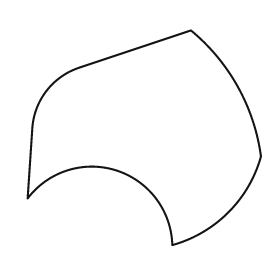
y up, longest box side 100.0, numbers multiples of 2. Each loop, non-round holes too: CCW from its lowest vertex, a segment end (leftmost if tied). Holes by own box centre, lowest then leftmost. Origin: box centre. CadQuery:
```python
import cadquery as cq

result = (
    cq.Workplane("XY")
    .moveTo(12.0, -46.0)
    .threePointArc((36.0, -32.0), (50.0, -8.0))
    .threePointArc((40.0, 22.0), (20.0, 46.0))
    .lineTo(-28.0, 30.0)
    .threePointArc((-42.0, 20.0), (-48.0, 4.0))
    .lineTo(-50.0, -26.0)
    .threePointArc((-12.0, -14.0), (12.0, -46.0))
    .close()
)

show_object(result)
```